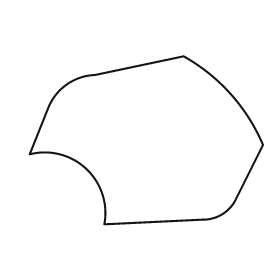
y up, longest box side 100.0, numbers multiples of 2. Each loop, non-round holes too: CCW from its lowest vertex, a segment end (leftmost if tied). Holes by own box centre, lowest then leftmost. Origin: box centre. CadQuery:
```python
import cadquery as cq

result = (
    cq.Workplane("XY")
    .moveTo(-18.0, -36.0)
    .lineTo(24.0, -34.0)
    .threePointArc((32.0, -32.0), (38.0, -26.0))
    .lineTo(50.0, -2.0)
    .threePointArc((36.0, 20.0), (16.0, 36.0))
    .lineTo(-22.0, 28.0)
    .threePointArc((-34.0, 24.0), (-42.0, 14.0))
    .lineTo(-50.0, -6.0)
    .threePointArc((-26.0, -12.0), (-18.0, -36.0))
    .close()
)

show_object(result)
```